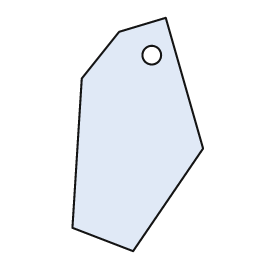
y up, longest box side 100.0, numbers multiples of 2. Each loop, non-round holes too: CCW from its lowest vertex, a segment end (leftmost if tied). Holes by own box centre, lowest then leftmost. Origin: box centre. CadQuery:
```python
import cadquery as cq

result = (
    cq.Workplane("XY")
    .moveTo(-2.0, -50.0)
    .lineTo(28.0, -6.0)
    .lineTo(12.0, 50.0)
    .lineTo(-8.0, 44.0)
    .lineTo(-24.0, 24.0)
    .lineTo(-28.0, -40.0)
    .close()
    .moveTo(6.0, 34.0)
    .circle(4.0)
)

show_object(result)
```